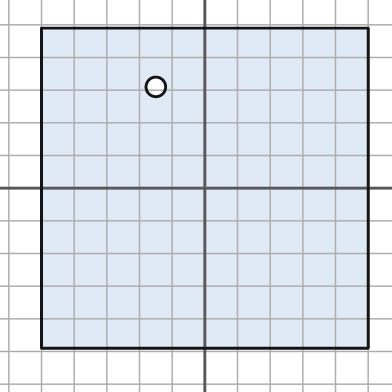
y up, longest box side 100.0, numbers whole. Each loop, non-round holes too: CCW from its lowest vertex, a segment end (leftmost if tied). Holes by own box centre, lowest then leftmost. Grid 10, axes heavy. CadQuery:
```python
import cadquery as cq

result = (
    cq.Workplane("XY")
    .moveTo(-50.0, -49.0)
    .lineTo(50.0, -49.0)
    .lineTo(50.0, 49.0)
    .lineTo(-50.0, 49.0)
    .close()
    .moveTo(-15.0, 31.0)
    .circle(3.0)
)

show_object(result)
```